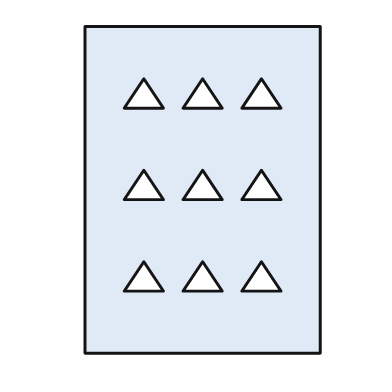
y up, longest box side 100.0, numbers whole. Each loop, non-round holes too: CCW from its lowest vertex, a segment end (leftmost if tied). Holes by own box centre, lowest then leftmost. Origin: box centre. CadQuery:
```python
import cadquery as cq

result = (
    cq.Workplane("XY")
    .moveTo(-36.0, -50.0)
    .lineTo(36.0, -50.0)
    .lineTo(36.0, 50.0)
    .lineTo(-36.0, 50.0)
    .close()
    .moveTo(-24.0, -31.0)
    .lineTo(-12.0, -31.0)
    .lineTo(-18.0, -22.0)
    .close()
    .moveTo(-6.0, -31.0)
    .lineTo(6.0, -31.0)
    .lineTo(0.0, -22.0)
    .close()
    .moveTo(12.0, -31.0)
    .lineTo(24.0, -31.0)
    .lineTo(18.0, -22.0)
    .close()
    .moveTo(-24.0, -3.0)
    .lineTo(-12.0, -3.0)
    .lineTo(-18.0, 6.0)
    .close()
    .moveTo(-6.0, -3.0)
    .lineTo(6.0, -3.0)
    .lineTo(0.0, 6.0)
    .close()
    .moveTo(12.0, -3.0)
    .lineTo(24.0, -3.0)
    .lineTo(18.0, 6.0)
    .close()
    .moveTo(-24.0, 25.0)
    .lineTo(-12.0, 25.0)
    .lineTo(-18.0, 34.0)
    .close()
    .moveTo(-6.0, 25.0)
    .lineTo(6.0, 25.0)
    .lineTo(0.0, 34.0)
    .close()
    .moveTo(12.0, 25.0)
    .lineTo(24.0, 25.0)
    .lineTo(18.0, 34.0)
    .close()
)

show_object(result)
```